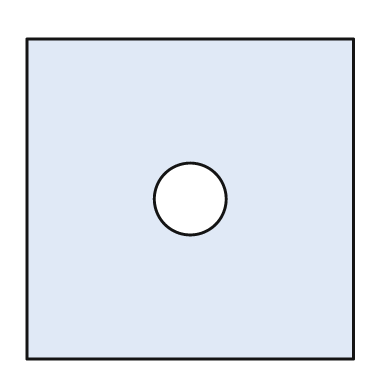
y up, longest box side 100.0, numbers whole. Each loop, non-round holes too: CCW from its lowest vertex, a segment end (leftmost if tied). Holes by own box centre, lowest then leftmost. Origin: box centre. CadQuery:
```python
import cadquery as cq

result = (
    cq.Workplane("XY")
    .moveTo(-50.0, -49.0)
    .lineTo(50.0, -49.0)
    .lineTo(50.0, 49.0)
    .lineTo(-50.0, 49.0)
    .close()
    .moveTo(0.0, 0.0)
    .circle(11.0)
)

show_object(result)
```